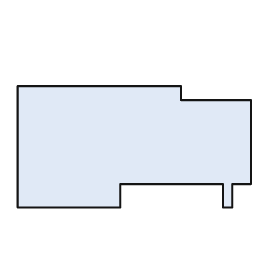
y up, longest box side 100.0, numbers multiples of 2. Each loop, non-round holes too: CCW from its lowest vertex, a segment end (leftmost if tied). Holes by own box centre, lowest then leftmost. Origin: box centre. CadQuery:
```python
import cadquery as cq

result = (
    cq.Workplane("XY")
    .moveTo(-50.0, -26.0)
    .lineTo(-6.0, -26.0)
    .lineTo(-6.0, -16.0)
    .lineTo(38.0, -16.0)
    .lineTo(38.0, -26.0)
    .lineTo(42.0, -26.0)
    .lineTo(42.0, -16.0)
    .lineTo(50.0, -16.0)
    .lineTo(50.0, 20.0)
    .lineTo(20.0, 20.0)
    .lineTo(20.0, 26.0)
    .lineTo(-50.0, 26.0)
    .close()
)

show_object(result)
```